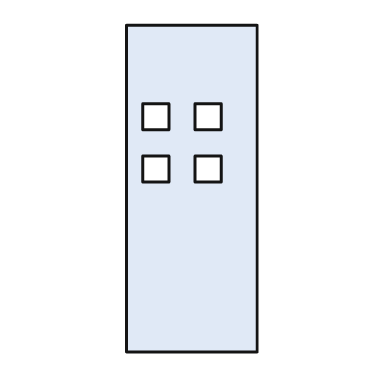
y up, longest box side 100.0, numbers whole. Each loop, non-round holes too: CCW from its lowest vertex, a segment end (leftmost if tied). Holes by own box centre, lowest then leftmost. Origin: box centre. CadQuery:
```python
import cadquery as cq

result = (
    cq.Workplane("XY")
    .moveTo(-20.0, -50.0)
    .lineTo(20.0, -50.0)
    .lineTo(20.0, 50.0)
    .lineTo(-20.0, 50.0)
    .close()
    .moveTo(-15.0, 2.0)
    .lineTo(-7.0, 2.0)
    .lineTo(-7.0, 10.0)
    .lineTo(-15.0, 10.0)
    .close()
    .moveTo(1.0, 2.0)
    .lineTo(9.0, 2.0)
    .lineTo(9.0, 10.0)
    .lineTo(1.0, 10.0)
    .close()
    .moveTo(-15.0, 18.0)
    .lineTo(-7.0, 18.0)
    .lineTo(-7.0, 26.0)
    .lineTo(-15.0, 26.0)
    .close()
    .moveTo(1.0, 18.0)
    .lineTo(9.0, 18.0)
    .lineTo(9.0, 26.0)
    .lineTo(1.0, 26.0)
    .close()
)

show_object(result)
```